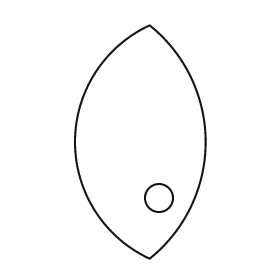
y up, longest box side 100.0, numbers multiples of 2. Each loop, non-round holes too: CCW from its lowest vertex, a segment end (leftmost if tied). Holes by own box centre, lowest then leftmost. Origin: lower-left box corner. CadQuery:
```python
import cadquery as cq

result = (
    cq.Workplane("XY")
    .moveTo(32.0, 0.0)
    .threePointArc((56.0, 50.0), (32.0, 100.0))
    .threePointArc((0.0, 50.0), (32.0, 0.0))
    .close()
    .moveTo(36.0, 26.0)
    .circle(6.0)
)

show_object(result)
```